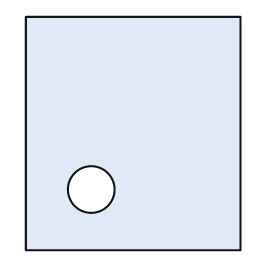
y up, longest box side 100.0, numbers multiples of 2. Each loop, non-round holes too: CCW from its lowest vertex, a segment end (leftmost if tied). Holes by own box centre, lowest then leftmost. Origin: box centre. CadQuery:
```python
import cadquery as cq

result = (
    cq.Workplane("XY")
    .moveTo(-46.0, -50.0)
    .lineTo(46.0, -50.0)
    .lineTo(46.0, 50.0)
    .lineTo(-46.0, 50.0)
    .close()
    .moveTo(-18.0, -24.0)
    .circle(10.0)
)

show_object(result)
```